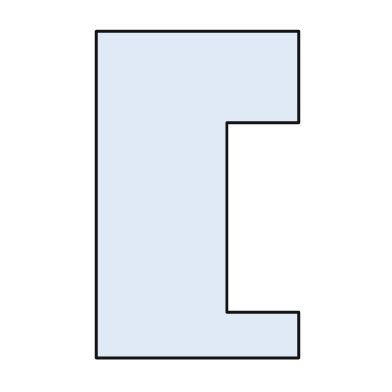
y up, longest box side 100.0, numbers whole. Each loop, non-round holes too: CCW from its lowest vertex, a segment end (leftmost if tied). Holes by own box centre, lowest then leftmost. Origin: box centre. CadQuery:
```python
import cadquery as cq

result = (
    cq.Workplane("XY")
    .moveTo(-31.0, -50.0)
    .lineTo(31.0, -50.0)
    .lineTo(31.0, -36.0)
    .lineTo(9.0, -36.0)
    .lineTo(9.0, 22.0)
    .lineTo(31.0, 22.0)
    .lineTo(31.0, 50.0)
    .lineTo(-31.0, 50.0)
    .close()
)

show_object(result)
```